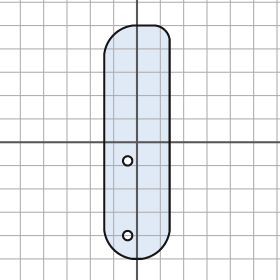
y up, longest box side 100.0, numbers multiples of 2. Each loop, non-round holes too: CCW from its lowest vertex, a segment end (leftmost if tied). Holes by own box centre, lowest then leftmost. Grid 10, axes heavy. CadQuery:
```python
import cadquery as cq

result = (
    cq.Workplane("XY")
    .moveTo(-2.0, -50.0)
    .lineTo(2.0, -50.0)
    .threePointArc((10.0, -46.0), (14.0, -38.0))
    .lineTo(14.0, 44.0)
    .threePointArc((12.0, 48.0), (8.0, 50.0))
    .lineTo(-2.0, 50.0)
    .threePointArc((-10.0, 46.0), (-14.0, 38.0))
    .lineTo(-14.0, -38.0)
    .threePointArc((-10.0, -46.0), (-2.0, -50.0))
    .close()
    .moveTo(-4.0, -40.0)
    .circle(2.0)
    .moveTo(-4.0, -8.0)
    .circle(2.0)
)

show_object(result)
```